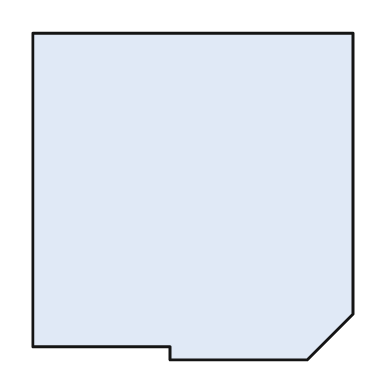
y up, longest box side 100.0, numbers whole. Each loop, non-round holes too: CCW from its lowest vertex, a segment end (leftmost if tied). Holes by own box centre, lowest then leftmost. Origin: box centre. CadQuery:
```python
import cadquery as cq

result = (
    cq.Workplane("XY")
    .moveTo(-7.0, -50.0)
    .lineTo(35.0, -50.0)
    .lineTo(49.0, -36.0)
    .lineTo(49.0, 50.0)
    .lineTo(-49.0, 50.0)
    .lineTo(-49.0, -46.0)
    .lineTo(-7.0, -46.0)
    .close()
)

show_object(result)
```